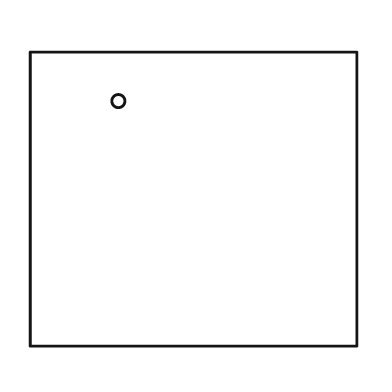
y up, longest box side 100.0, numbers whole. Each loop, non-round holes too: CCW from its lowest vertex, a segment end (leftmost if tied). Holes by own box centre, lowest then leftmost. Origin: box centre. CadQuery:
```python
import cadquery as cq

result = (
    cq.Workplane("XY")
    .moveTo(-50.0, -45.0)
    .lineTo(50.0, -45.0)
    .lineTo(50.0, 45.0)
    .lineTo(-50.0, 45.0)
    .close()
    .moveTo(-23.0, 30.0)
    .circle(2.0)
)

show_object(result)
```